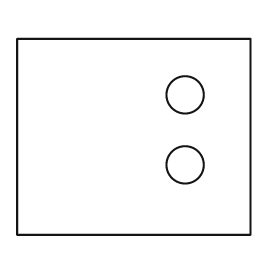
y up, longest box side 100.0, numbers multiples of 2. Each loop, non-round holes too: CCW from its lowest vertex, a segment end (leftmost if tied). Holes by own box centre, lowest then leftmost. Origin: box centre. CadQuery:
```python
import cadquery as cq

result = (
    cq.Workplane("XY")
    .moveTo(-50.0, -42.0)
    .lineTo(50.0, -42.0)
    .lineTo(50.0, 42.0)
    .lineTo(-50.0, 42.0)
    .close()
    .moveTo(22.0, -12.0)
    .circle(8.0)
    .moveTo(22.0, 18.0)
    .circle(8.0)
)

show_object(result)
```